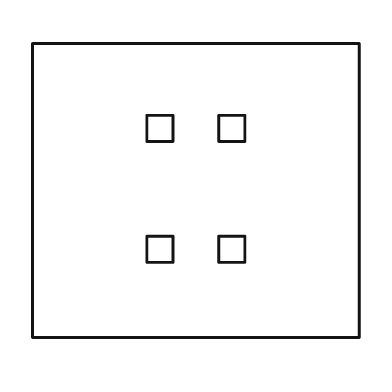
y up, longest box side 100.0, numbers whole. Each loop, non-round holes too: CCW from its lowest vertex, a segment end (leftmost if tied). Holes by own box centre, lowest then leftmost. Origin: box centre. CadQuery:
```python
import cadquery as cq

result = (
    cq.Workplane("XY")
    .moveTo(-50.0, -45.0)
    .lineTo(50.0, -45.0)
    .lineTo(50.0, 45.0)
    .lineTo(-50.0, 45.0)
    .close()
    .moveTo(-15.0, -22.0)
    .lineTo(-7.0, -22.0)
    .lineTo(-7.0, -14.0)
    .lineTo(-15.0, -14.0)
    .close()
    .moveTo(7.0, -22.0)
    .lineTo(15.0, -22.0)
    .lineTo(15.0, -14.0)
    .lineTo(7.0, -14.0)
    .close()
    .moveTo(-15.0, 15.0)
    .lineTo(-7.0, 15.0)
    .lineTo(-7.0, 23.0)
    .lineTo(-15.0, 23.0)
    .close()
    .moveTo(7.0, 15.0)
    .lineTo(15.0, 15.0)
    .lineTo(15.0, 23.0)
    .lineTo(7.0, 23.0)
    .close()
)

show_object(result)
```